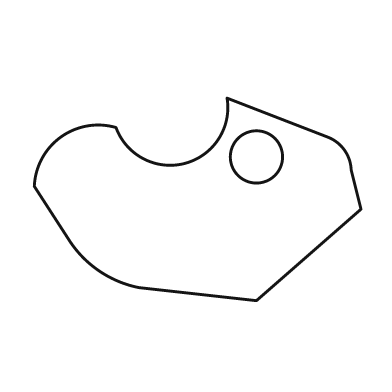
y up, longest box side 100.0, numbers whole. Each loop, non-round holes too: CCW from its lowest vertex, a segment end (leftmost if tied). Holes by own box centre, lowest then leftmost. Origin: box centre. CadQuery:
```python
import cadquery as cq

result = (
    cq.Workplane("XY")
    .moveTo(18.0, -31.0)
    .lineTo(50.0, -3.0)
    .lineTo(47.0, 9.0)
    .threePointArc((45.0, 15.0), (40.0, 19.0))
    .lineTo(9.0, 31.0)
    .threePointArc((-4.0, 11.0), (-25.0, 22.0))
    .threePointArc((-42.0, 19.0), (-50.0, 4.0))
    .lineTo(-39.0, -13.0)
    .threePointArc((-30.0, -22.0), (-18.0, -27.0))
    .close()
    .moveTo(18.0, 13.0)
    .circle(8.0)
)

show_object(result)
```